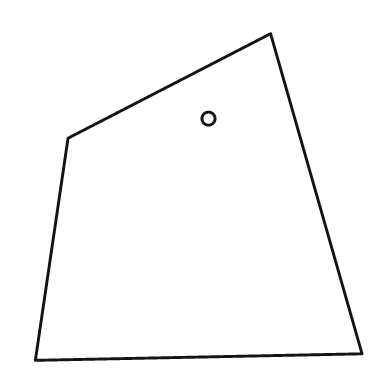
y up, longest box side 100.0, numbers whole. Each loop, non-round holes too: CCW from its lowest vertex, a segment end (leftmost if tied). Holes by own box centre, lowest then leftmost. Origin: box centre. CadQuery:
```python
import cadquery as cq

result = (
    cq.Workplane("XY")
    .moveTo(-50.0, -50.0)
    .lineTo(50.0, -48.0)
    .lineTo(22.0, 50.0)
    .lineTo(-40.0, 18.0)
    .close()
    .moveTo(3.0, 24.0)
    .circle(2.0)
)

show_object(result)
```